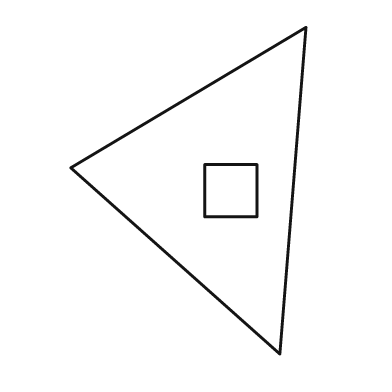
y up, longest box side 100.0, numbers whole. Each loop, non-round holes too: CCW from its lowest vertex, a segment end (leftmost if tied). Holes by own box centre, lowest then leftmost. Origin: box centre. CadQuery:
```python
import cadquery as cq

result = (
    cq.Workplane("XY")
    .moveTo(28.0, -50.0)
    .lineTo(36.0, 50.0)
    .lineTo(-36.0, 7.0)
    .close()
    .moveTo(5.0, -8.0)
    .lineTo(21.0, -8.0)
    .lineTo(21.0, 8.0)
    .lineTo(5.0, 8.0)
    .close()
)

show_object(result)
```